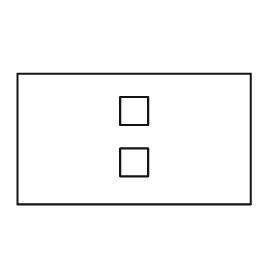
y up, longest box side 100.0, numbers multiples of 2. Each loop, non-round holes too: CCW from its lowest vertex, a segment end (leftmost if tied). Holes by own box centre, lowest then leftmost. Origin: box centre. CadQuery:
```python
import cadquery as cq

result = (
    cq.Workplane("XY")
    .moveTo(-50.0, -28.0)
    .lineTo(50.0, -28.0)
    .lineTo(50.0, 28.0)
    .lineTo(-50.0, 28.0)
    .close()
    .moveTo(-6.0, -16.0)
    .lineTo(6.0, -16.0)
    .lineTo(6.0, -4.0)
    .lineTo(-6.0, -4.0)
    .close()
    .moveTo(-6.0, 6.0)
    .lineTo(6.0, 6.0)
    .lineTo(6.0, 18.0)
    .lineTo(-6.0, 18.0)
    .close()
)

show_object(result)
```